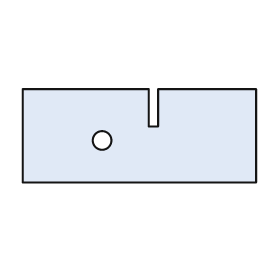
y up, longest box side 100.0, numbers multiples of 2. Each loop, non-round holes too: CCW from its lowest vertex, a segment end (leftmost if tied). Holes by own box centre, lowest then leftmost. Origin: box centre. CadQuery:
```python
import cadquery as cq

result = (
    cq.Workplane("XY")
    .moveTo(-50.0, -20.0)
    .lineTo(50.0, -20.0)
    .lineTo(50.0, 20.0)
    .lineTo(8.0, 20.0)
    .lineTo(8.0, 4.0)
    .lineTo(4.0, 4.0)
    .lineTo(4.0, 20.0)
    .lineTo(-50.0, 20.0)
    .close()
    .moveTo(-16.0, -2.0)
    .circle(4.0)
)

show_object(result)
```